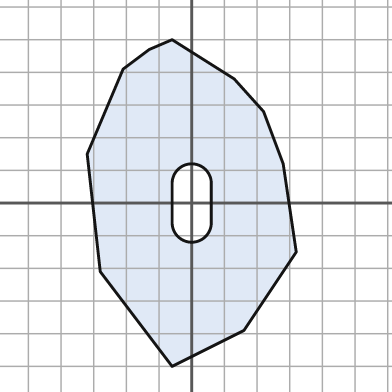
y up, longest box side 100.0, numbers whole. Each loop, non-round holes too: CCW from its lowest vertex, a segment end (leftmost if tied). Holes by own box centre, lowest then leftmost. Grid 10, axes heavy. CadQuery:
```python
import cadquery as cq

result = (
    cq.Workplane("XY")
    .moveTo(-6.0, -50.0)
    .lineTo(16.0, -39.0)
    .lineTo(32.0, -15.0)
    .lineTo(28.0, 12.0)
    .lineTo(22.0, 28.0)
    .lineTo(13.0, 38.0)
    .lineTo(-6.0, 50.0)
    .lineTo(-13.0, 47.0)
    .lineTo(-21.0, 41.0)
    .lineTo(-32.0, 15.0)
    .lineTo(-28.0, -21.0)
    .close()
    .moveTo(-6.0, -6.0)
    .threePointArc((0.0, -12.0), (6.0, -6.0))
    .lineTo(6.0, 6.0)
    .threePointArc((0.0, 12.0), (-6.0, 6.0))
    .close()
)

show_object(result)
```